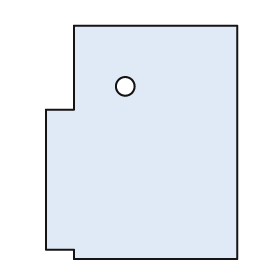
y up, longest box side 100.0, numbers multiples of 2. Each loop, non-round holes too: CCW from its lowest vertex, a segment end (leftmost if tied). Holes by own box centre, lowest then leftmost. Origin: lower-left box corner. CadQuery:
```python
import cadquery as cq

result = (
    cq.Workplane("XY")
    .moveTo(12.0, 0.0)
    .lineTo(82.0, 0.0)
    .lineTo(82.0, 100.0)
    .lineTo(12.0, 100.0)
    .lineTo(12.0, 64.0)
    .lineTo(0.0, 64.0)
    .lineTo(0.0, 4.0)
    .lineTo(12.0, 4.0)
    .close()
    .moveTo(34.0, 74.0)
    .circle(4.0)
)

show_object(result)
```